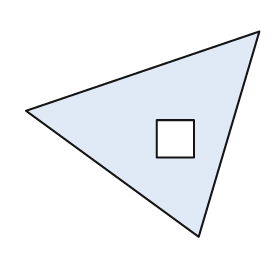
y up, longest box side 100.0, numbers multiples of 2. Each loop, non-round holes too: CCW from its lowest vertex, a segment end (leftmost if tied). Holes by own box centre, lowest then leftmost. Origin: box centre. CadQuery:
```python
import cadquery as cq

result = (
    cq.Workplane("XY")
    .moveTo(24.0, -44.0)
    .lineTo(50.0, 44.0)
    .lineTo(-50.0, 10.0)
    .close()
    .moveTo(6.0, -10.0)
    .lineTo(22.0, -10.0)
    .lineTo(22.0, 6.0)
    .lineTo(6.0, 6.0)
    .close()
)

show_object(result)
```